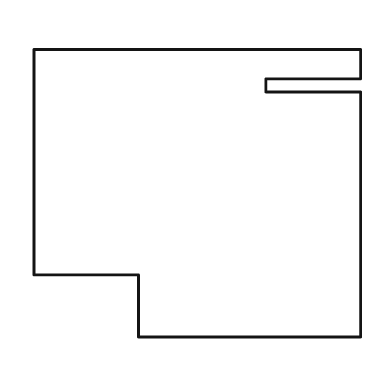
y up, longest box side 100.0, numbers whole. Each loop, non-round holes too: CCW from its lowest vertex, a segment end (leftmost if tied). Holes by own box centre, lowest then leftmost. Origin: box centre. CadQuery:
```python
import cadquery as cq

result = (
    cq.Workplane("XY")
    .moveTo(-18.0, -44.0)
    .lineTo(50.0, -44.0)
    .lineTo(50.0, 31.0)
    .lineTo(21.0, 31.0)
    .lineTo(21.0, 35.0)
    .lineTo(50.0, 35.0)
    .lineTo(50.0, 44.0)
    .lineTo(-50.0, 44.0)
    .lineTo(-50.0, -25.0)
    .lineTo(-18.0, -25.0)
    .close()
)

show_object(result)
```